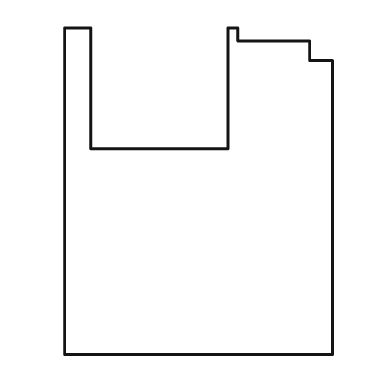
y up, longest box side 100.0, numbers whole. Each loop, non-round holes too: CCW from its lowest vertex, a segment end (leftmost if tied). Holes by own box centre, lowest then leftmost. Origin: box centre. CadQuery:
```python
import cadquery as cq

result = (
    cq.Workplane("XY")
    .moveTo(-41.0, -50.0)
    .lineTo(41.0, -50.0)
    .lineTo(41.0, 40.0)
    .lineTo(34.0, 40.0)
    .lineTo(34.0, 46.0)
    .lineTo(12.0, 46.0)
    .lineTo(12.0, 50.0)
    .lineTo(9.0, 50.0)
    .lineTo(9.0, 13.0)
    .lineTo(-33.0, 13.0)
    .lineTo(-33.0, 50.0)
    .lineTo(-41.0, 50.0)
    .close()
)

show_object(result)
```